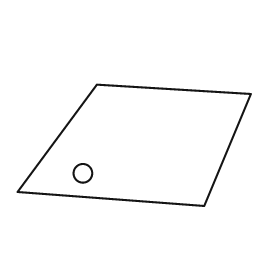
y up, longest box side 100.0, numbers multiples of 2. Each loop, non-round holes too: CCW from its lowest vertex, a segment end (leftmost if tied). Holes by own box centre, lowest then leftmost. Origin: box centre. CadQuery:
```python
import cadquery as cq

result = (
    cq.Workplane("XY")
    .moveTo(30.0, -26.0)
    .lineTo(50.0, 22.0)
    .lineTo(-16.0, 26.0)
    .lineTo(-50.0, -20.0)
    .close()
    .moveTo(-22.0, -12.0)
    .circle(4.0)
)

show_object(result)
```